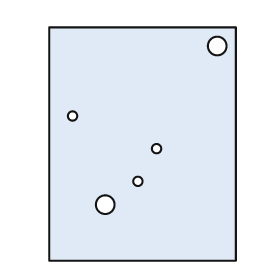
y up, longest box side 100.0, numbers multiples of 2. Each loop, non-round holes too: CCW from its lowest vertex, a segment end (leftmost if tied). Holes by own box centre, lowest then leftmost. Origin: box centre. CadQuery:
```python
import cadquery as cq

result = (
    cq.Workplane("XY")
    .moveTo(-40.0, -50.0)
    .lineTo(40.0, -50.0)
    .lineTo(40.0, 50.0)
    .lineTo(-40.0, 50.0)
    .close()
    .moveTo(-16.0, -26.0)
    .circle(4.0)
    .moveTo(-2.0, -16.0)
    .circle(2.0)
    .moveTo(6.0, -2.0)
    .circle(2.0)
    .moveTo(-30.0, 12.0)
    .circle(2.0)
    .moveTo(32.0, 42.0)
    .circle(4.0)
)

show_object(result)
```